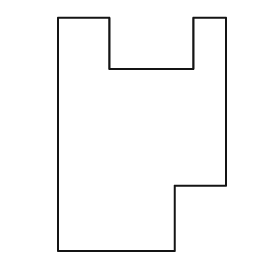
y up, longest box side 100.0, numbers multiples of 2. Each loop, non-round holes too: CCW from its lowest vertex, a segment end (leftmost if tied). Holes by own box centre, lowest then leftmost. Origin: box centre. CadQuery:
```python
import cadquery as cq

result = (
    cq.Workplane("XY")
    .moveTo(-36.0, -50.0)
    .lineTo(14.0, -50.0)
    .lineTo(14.0, -22.0)
    .lineTo(36.0, -22.0)
    .lineTo(36.0, 50.0)
    .lineTo(22.0, 50.0)
    .lineTo(22.0, 28.0)
    .lineTo(-14.0, 28.0)
    .lineTo(-14.0, 50.0)
    .lineTo(-36.0, 50.0)
    .close()
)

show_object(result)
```